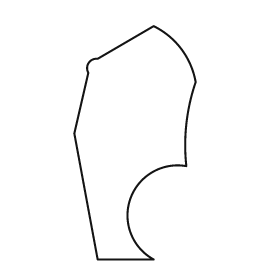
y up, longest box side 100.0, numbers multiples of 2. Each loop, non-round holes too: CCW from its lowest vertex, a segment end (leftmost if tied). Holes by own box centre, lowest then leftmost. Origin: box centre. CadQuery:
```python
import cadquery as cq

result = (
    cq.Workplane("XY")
    .moveTo(-16.0, -50.0)
    .lineTo(8.0, -50.0)
    .threePointArc((-2.0, -24.0), (22.0, -10.0))
    .threePointArc((22.0, 8.0), (26.0, 26.0))
    .threePointArc((20.0, 40.0), (8.0, 50.0))
    .lineTo(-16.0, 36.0)
    .threePointArc((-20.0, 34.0), (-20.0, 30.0))
    .lineTo(-26.0, 4.0)
    .close()
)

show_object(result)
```